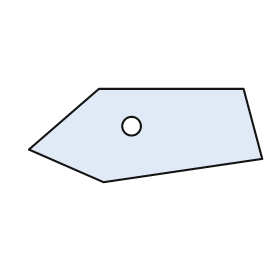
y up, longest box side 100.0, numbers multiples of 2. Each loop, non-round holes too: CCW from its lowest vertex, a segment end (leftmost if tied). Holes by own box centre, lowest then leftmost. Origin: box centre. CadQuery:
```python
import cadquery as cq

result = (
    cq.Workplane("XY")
    .moveTo(-18.0, -20.0)
    .lineTo(50.0, -10.0)
    .lineTo(42.0, 20.0)
    .lineTo(-20.0, 20.0)
    .lineTo(-50.0, -6.0)
    .close()
    .moveTo(-6.0, 4.0)
    .circle(4.0)
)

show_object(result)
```